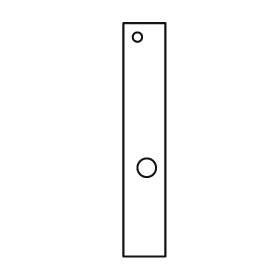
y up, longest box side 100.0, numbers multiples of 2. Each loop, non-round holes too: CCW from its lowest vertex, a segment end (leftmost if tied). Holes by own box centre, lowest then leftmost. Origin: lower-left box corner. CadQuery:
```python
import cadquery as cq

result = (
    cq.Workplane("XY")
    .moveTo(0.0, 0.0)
    .lineTo(18.0, 0.0)
    .lineTo(18.0, 100.0)
    .lineTo(0.0, 100.0)
    .close()
    .moveTo(10.0, 38.0)
    .circle(4.0)
    .moveTo(6.0, 94.0)
    .circle(2.0)
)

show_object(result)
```